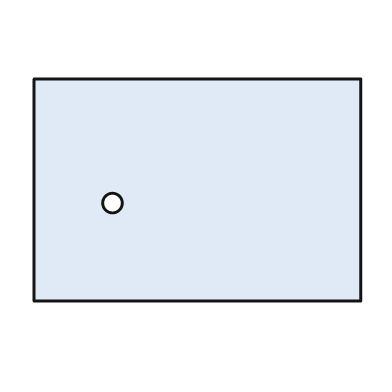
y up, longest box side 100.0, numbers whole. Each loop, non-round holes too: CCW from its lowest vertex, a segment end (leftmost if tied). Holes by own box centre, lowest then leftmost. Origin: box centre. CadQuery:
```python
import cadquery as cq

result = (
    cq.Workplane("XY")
    .moveTo(-50.0, -34.0)
    .lineTo(50.0, -34.0)
    .lineTo(50.0, 34.0)
    .lineTo(-50.0, 34.0)
    .close()
    .moveTo(-26.0, -4.0)
    .circle(3.0)
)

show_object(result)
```